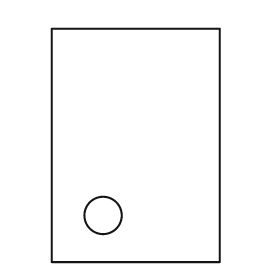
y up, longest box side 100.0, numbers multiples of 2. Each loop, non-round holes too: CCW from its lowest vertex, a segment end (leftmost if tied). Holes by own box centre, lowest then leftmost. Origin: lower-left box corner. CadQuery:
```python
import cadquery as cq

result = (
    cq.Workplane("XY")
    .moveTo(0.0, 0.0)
    .lineTo(72.0, 0.0)
    .lineTo(72.0, 100.0)
    .lineTo(0.0, 100.0)
    .close()
    .moveTo(22.0, 20.0)
    .circle(8.0)
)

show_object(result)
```